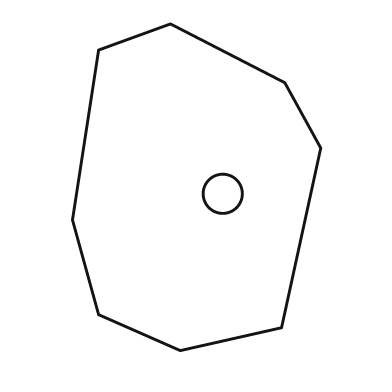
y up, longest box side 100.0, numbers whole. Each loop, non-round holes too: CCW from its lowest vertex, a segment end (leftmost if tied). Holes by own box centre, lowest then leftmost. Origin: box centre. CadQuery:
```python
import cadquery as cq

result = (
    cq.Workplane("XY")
    .moveTo(-5.0, -50.0)
    .lineTo(26.0, -43.0)
    .lineTo(38.0, 12.0)
    .lineTo(27.0, 32.0)
    .lineTo(-8.0, 50.0)
    .lineTo(-30.0, 42.0)
    .lineTo(-38.0, -10.0)
    .lineTo(-30.0, -39.0)
    .close()
    .moveTo(8.0, -2.0)
    .circle(6.0)
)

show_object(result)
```